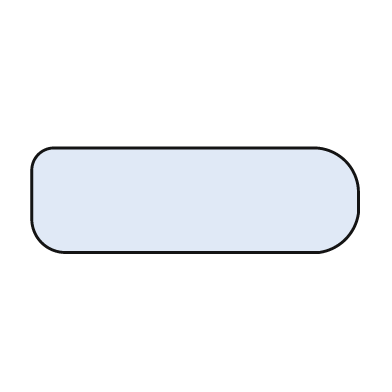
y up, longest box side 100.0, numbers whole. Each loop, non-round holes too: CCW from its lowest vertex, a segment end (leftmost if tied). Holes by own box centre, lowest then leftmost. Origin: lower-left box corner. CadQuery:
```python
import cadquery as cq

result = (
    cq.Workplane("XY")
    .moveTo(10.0, 0.0)
    .lineTo(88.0, 0.0)
    .threePointArc((96.0, 4.0), (100.0, 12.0))
    .lineTo(100.0, 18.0)
    .threePointArc((96.0, 28.0), (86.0, 32.0))
    .lineTo(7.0, 32.0)
    .threePointArc((2.0, 30.0), (0.0, 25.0))
    .lineTo(0.0, 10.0)
    .threePointArc((3.0, 3.0), (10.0, 0.0))
    .close()
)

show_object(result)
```